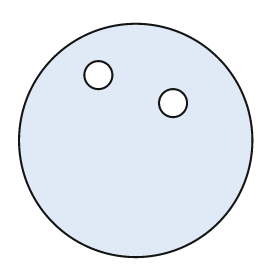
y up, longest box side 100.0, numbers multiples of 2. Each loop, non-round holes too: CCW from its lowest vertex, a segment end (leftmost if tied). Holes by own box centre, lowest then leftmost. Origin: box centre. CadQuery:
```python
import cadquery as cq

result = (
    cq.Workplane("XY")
    .moveTo(0.0, 0.0)
    .circle(50.0)
    .moveTo(16.0, 16.0)
    .circle(6.0)
    .moveTo(-16.0, 28.0)
    .circle(6.0)
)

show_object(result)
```